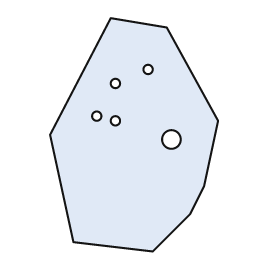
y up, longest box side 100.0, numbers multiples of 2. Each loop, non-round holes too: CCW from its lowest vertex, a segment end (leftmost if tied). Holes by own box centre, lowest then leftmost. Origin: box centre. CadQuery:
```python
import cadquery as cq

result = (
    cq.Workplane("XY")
    .moveTo(8.0, -50.0)
    .lineTo(24.0, -34.0)
    .lineTo(30.0, -22.0)
    .lineTo(36.0, 6.0)
    .lineTo(14.0, 46.0)
    .lineTo(-10.0, 50.0)
    .lineTo(-36.0, 0.0)
    .lineTo(-26.0, -46.0)
    .close()
    .moveTo(16.0, -2.0)
    .circle(4.0)
    .moveTo(-8.0, 6.0)
    .circle(2.0)
    .moveTo(-16.0, 8.0)
    .circle(2.0)
    .moveTo(-8.0, 22.0)
    .circle(2.0)
    .moveTo(6.0, 28.0)
    .circle(2.0)
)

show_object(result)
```